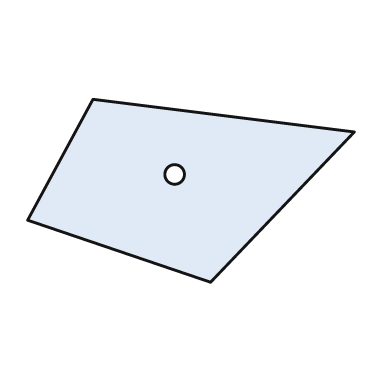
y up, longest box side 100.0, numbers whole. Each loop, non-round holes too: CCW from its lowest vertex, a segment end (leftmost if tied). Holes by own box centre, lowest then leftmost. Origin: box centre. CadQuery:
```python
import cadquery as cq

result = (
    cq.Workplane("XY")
    .moveTo(6.0, -28.0)
    .lineTo(50.0, 18.0)
    .lineTo(-30.0, 28.0)
    .lineTo(-50.0, -9.0)
    .close()
    .moveTo(-5.0, 5.0)
    .circle(3.0)
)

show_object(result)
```